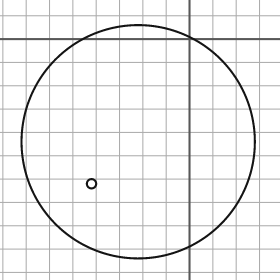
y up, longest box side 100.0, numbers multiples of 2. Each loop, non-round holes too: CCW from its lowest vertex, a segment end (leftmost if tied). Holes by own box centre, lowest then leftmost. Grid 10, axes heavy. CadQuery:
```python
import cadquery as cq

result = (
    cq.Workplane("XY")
    .moveTo(-22.0, -44.0)
    .circle(50.0)
    .moveTo(-42.0, -62.0)
    .circle(2.0)
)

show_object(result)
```